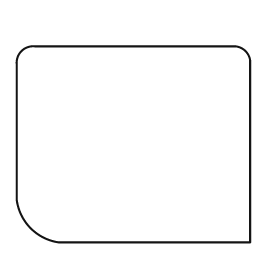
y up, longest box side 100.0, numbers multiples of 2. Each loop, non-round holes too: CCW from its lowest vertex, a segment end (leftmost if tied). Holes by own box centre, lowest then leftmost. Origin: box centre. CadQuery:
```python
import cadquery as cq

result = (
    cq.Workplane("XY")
    .moveTo(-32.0, -42.0)
    .lineTo(50.0, -42.0)
    .lineTo(50.0, 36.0)
    .threePointArc((48.0, 40.0), (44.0, 42.0))
    .lineTo(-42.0, 42.0)
    .threePointArc((-48.0, 40.0), (-50.0, 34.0))
    .lineTo(-50.0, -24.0)
    .threePointArc((-44.0, -36.0), (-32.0, -42.0))
    .close()
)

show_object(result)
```